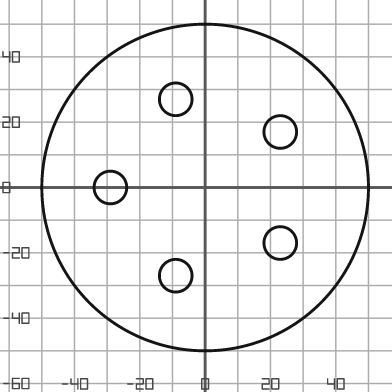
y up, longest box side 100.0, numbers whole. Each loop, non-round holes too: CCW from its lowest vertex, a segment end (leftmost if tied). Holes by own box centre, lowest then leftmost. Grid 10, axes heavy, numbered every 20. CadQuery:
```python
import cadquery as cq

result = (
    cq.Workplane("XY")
    .moveTo(0.0, 0.0)
    .circle(50.0)
    .moveTo(-9.0, -27.0)
    .circle(5.0)
    .moveTo(23.0, -17.0)
    .circle(5.0)
    .moveTo(-29.0, 0.0)
    .circle(5.0)
    .moveTo(23.0, 17.0)
    .circle(5.0)
    .moveTo(-9.0, 27.0)
    .circle(5.0)
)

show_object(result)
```